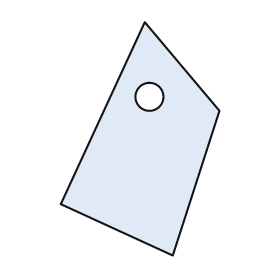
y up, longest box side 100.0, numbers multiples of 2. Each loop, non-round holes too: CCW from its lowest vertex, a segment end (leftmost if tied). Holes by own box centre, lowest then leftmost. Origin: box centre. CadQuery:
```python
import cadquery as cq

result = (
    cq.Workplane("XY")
    .moveTo(14.0, -50.0)
    .lineTo(34.0, 12.0)
    .lineTo(2.0, 50.0)
    .lineTo(-34.0, -28.0)
    .close()
    .moveTo(4.0, 18.0)
    .circle(6.0)
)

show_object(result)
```